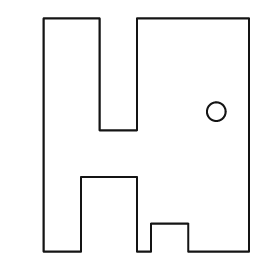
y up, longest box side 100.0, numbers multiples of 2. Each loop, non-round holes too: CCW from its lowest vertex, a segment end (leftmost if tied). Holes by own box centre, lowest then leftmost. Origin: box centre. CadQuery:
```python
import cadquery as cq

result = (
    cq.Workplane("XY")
    .moveTo(-44.0, -50.0)
    .lineTo(-28.0, -50.0)
    .lineTo(-28.0, -18.0)
    .lineTo(-4.0, -18.0)
    .lineTo(-4.0, -50.0)
    .lineTo(2.0, -50.0)
    .lineTo(2.0, -38.0)
    .lineTo(18.0, -38.0)
    .lineTo(18.0, -50.0)
    .lineTo(44.0, -50.0)
    .lineTo(44.0, 50.0)
    .lineTo(-4.0, 50.0)
    .lineTo(-4.0, 2.0)
    .lineTo(-20.0, 2.0)
    .lineTo(-20.0, 50.0)
    .lineTo(-44.0, 50.0)
    .close()
    .moveTo(30.0, 10.0)
    .circle(4.0)
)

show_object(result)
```